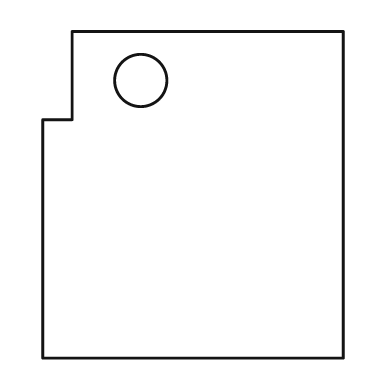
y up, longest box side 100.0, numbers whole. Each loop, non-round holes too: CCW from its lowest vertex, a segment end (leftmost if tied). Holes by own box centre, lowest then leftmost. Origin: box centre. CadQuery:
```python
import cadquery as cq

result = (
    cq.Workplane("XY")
    .moveTo(-46.0, -50.0)
    .lineTo(46.0, -50.0)
    .lineTo(46.0, 50.0)
    .lineTo(-37.0, 50.0)
    .lineTo(-37.0, 23.0)
    .lineTo(-46.0, 23.0)
    .close()
    .moveTo(-16.0, 35.0)
    .circle(8.0)
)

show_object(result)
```